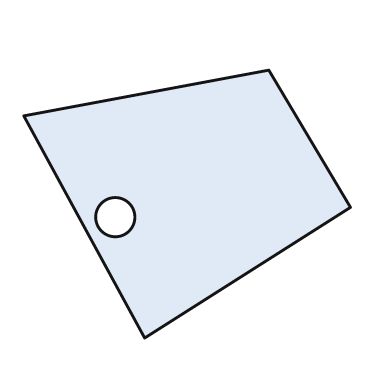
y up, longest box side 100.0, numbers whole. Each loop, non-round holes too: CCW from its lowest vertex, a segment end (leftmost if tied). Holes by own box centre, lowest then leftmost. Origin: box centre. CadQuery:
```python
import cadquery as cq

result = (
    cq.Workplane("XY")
    .moveTo(-13.0, -41.0)
    .lineTo(50.0, -1.0)
    .lineTo(25.0, 41.0)
    .lineTo(-50.0, 27.0)
    .close()
    .moveTo(-22.0, -4.0)
    .circle(6.0)
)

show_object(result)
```